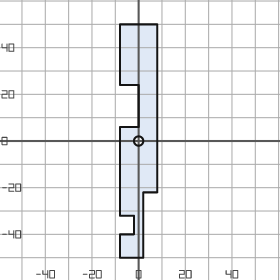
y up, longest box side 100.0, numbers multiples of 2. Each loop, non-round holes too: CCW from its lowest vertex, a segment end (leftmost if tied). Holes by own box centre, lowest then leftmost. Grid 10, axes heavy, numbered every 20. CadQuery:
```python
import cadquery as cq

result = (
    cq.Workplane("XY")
    .moveTo(-8.0, -50.0)
    .lineTo(2.0, -50.0)
    .lineTo(2.0, -22.0)
    .lineTo(8.0, -22.0)
    .lineTo(8.0, 50.0)
    .lineTo(-8.0, 50.0)
    .lineTo(-8.0, 24.0)
    .lineTo(0.0, 24.0)
    .lineTo(0.0, 6.0)
    .lineTo(-8.0, 6.0)
    .lineTo(-8.0, -32.0)
    .lineTo(-2.0, -32.0)
    .lineTo(-2.0, -40.0)
    .lineTo(-8.0, -40.0)
    .close()
    .moveTo(0.0, 0.0)
    .circle(2.0)
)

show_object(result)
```